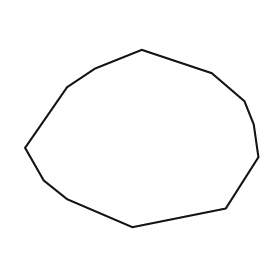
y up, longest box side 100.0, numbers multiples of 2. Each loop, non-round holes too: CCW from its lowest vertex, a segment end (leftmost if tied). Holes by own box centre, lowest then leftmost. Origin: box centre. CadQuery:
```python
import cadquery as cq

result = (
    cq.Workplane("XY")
    .moveTo(-4.0, -38.0)
    .lineTo(36.0, -30.0)
    .lineTo(50.0, -8.0)
    .lineTo(48.0, 6.0)
    .lineTo(44.0, 16.0)
    .lineTo(30.0, 28.0)
    .lineTo(0.0, 38.0)
    .lineTo(-20.0, 30.0)
    .lineTo(-32.0, 22.0)
    .lineTo(-50.0, -4.0)
    .lineTo(-42.0, -18.0)
    .lineTo(-32.0, -26.0)
    .close()
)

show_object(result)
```